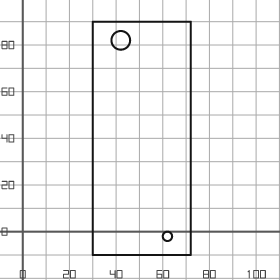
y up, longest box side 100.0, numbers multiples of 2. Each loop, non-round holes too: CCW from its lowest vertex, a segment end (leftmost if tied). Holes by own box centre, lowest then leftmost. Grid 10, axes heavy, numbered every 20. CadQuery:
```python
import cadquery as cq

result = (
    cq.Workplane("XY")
    .moveTo(30.0, -10.0)
    .lineTo(72.0, -10.0)
    .lineTo(72.0, 90.0)
    .lineTo(30.0, 90.0)
    .close()
    .moveTo(62.0, -2.0)
    .circle(2.0)
    .moveTo(42.0, 82.0)
    .circle(4.0)
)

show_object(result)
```